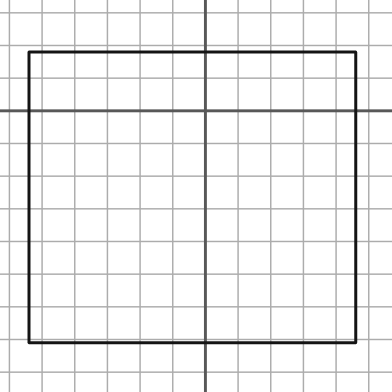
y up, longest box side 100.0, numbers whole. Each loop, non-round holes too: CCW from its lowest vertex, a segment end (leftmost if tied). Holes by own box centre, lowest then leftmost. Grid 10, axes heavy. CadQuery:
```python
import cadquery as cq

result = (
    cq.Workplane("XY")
    .moveTo(-54.0, -71.0)
    .lineTo(46.0, -71.0)
    .lineTo(46.0, 18.0)
    .lineTo(-54.0, 18.0)
    .close()
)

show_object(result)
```